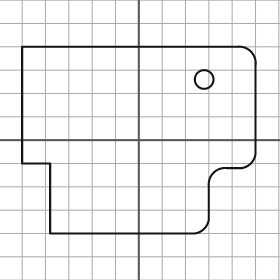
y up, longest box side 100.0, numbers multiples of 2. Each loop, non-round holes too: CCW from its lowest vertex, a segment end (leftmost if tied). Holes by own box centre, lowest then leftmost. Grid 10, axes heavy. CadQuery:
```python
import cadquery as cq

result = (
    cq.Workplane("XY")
    .moveTo(-38.0, -40.0)
    .lineTo(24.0, -40.0)
    .threePointArc((28.0, -38.0), (30.0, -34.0))
    .lineTo(30.0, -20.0)
    .threePointArc((32.0, -14.0), (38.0, -12.0))
    .lineTo(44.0, -12.0)
    .threePointArc((48.0, -10.0), (50.0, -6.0))
    .lineTo(50.0, 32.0)
    .threePointArc((48.0, 38.0), (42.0, 40.0))
    .lineTo(-50.0, 40.0)
    .lineTo(-50.0, -10.0)
    .lineTo(-38.0, -10.0)
    .close()
    .moveTo(28.0, 26.0)
    .circle(4.0)
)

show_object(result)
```